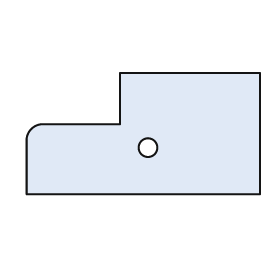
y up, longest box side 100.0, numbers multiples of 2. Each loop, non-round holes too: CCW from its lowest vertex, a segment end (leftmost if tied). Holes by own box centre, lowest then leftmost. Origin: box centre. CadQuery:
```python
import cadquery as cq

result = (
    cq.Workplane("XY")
    .moveTo(-50.0, -26.0)
    .lineTo(50.0, -26.0)
    .lineTo(50.0, 26.0)
    .lineTo(-10.0, 26.0)
    .lineTo(-10.0, 4.0)
    .lineTo(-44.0, 4.0)
    .threePointArc((-48.0, 2.0), (-50.0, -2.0))
    .close()
    .moveTo(2.0, -6.0)
    .circle(4.0)
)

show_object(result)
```